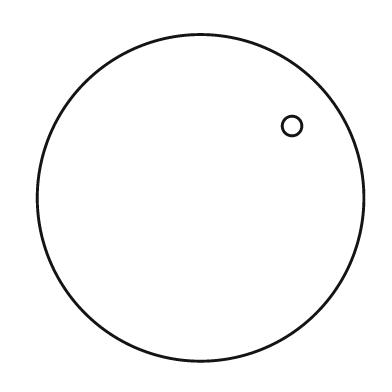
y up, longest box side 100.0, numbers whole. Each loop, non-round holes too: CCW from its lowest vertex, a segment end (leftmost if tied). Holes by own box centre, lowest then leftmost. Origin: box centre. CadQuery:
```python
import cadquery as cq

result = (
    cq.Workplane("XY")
    .moveTo(0.0, 0.0)
    .circle(50.0)
    .moveTo(28.0, 22.0)
    .circle(3.0)
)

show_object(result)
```